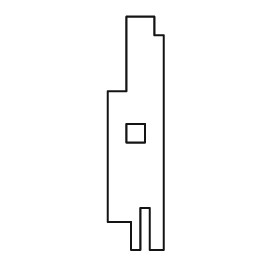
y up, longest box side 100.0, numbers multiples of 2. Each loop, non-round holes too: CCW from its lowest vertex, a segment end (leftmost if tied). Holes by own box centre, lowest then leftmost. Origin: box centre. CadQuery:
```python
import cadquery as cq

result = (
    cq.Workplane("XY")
    .moveTo(-2.0, -50.0)
    .lineTo(2.0, -50.0)
    .lineTo(2.0, -32.0)
    .lineTo(6.0, -32.0)
    .lineTo(6.0, -50.0)
    .lineTo(12.0, -50.0)
    .lineTo(12.0, 42.0)
    .lineTo(8.0, 42.0)
    .lineTo(8.0, 50.0)
    .lineTo(-4.0, 50.0)
    .lineTo(-4.0, 18.0)
    .lineTo(-12.0, 18.0)
    .lineTo(-12.0, -38.0)
    .lineTo(-2.0, -38.0)
    .close()
    .moveTo(-4.0, -4.0)
    .lineTo(4.0, -4.0)
    .lineTo(4.0, 4.0)
    .lineTo(-4.0, 4.0)
    .close()
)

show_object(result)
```